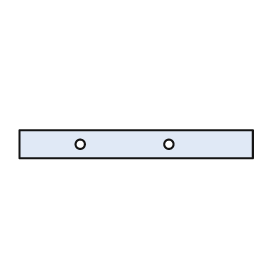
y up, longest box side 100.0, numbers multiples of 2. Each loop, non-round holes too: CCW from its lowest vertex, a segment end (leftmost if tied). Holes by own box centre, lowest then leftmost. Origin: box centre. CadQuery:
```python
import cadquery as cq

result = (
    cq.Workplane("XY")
    .moveTo(-50.0, -6.0)
    .lineTo(50.0, -6.0)
    .lineTo(50.0, 6.0)
    .lineTo(-50.0, 6.0)
    .close()
    .moveTo(-24.0, 0.0)
    .circle(2.0)
    .moveTo(14.0, 0.0)
    .circle(2.0)
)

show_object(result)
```